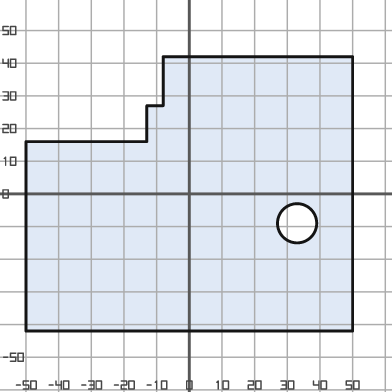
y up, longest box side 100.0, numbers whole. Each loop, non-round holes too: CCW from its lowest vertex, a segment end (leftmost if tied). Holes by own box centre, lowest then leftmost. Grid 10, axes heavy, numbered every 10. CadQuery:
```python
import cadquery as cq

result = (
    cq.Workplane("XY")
    .moveTo(-50.0, -42.0)
    .lineTo(50.0, -42.0)
    .lineTo(50.0, 42.0)
    .lineTo(-8.0, 42.0)
    .lineTo(-8.0, 27.0)
    .lineTo(-13.0, 27.0)
    .lineTo(-13.0, 16.0)
    .lineTo(-50.0, 16.0)
    .close()
    .moveTo(33.0, -9.0)
    .circle(6.0)
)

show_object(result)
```